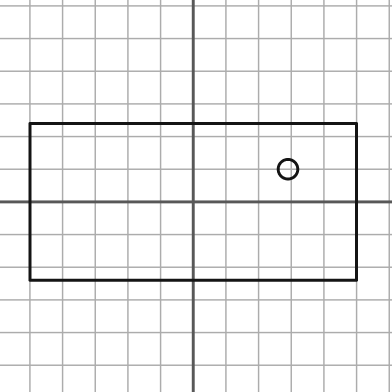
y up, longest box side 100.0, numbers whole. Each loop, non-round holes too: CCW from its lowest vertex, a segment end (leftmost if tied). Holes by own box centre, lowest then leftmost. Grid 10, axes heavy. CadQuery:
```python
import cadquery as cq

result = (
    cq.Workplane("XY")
    .moveTo(-50.0, -24.0)
    .lineTo(50.0, -24.0)
    .lineTo(50.0, 24.0)
    .lineTo(-50.0, 24.0)
    .close()
    .moveTo(29.0, 10.0)
    .circle(3.0)
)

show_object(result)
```